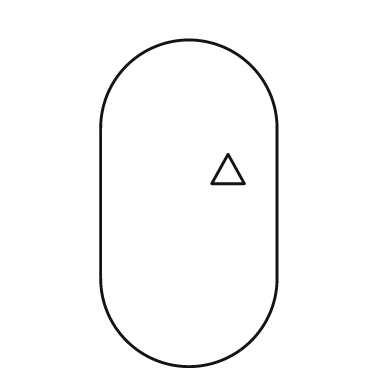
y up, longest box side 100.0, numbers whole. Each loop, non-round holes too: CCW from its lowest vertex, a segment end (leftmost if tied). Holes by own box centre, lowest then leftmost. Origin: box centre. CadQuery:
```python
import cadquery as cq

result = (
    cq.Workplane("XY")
    .moveTo(-27.0, -23.0)
    .threePointArc((0.0, -50.0), (27.0, -23.0))
    .lineTo(27.0, 23.0)
    .threePointArc((0.0, 50.0), (-27.0, 23.0))
    .close()
    .moveTo(7.0, 6.0)
    .lineTo(17.0, 6.0)
    .lineTo(12.0, 15.0)
    .close()
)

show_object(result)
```